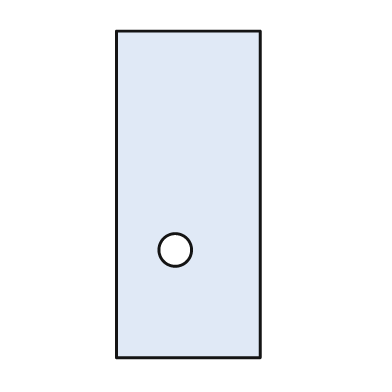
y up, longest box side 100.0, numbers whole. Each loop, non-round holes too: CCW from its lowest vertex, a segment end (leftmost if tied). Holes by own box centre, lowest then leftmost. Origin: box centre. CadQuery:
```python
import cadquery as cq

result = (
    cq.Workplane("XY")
    .moveTo(-22.0, -50.0)
    .lineTo(22.0, -50.0)
    .lineTo(22.0, 50.0)
    .lineTo(-22.0, 50.0)
    .close()
    .moveTo(-4.0, -17.0)
    .circle(5.0)
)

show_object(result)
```